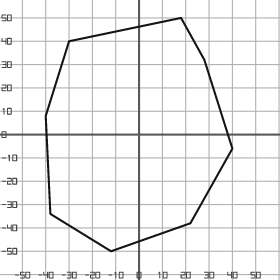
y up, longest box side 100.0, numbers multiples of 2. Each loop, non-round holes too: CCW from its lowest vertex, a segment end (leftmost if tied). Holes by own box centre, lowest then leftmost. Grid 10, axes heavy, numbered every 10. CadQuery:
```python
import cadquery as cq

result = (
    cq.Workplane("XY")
    .moveTo(-12.0, -50.0)
    .lineTo(22.0, -38.0)
    .lineTo(40.0, -6.0)
    .lineTo(28.0, 32.0)
    .lineTo(18.0, 50.0)
    .lineTo(-30.0, 40.0)
    .lineTo(-40.0, 8.0)
    .lineTo(-38.0, -34.0)
    .close()
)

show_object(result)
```